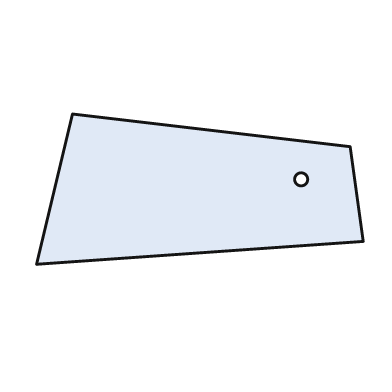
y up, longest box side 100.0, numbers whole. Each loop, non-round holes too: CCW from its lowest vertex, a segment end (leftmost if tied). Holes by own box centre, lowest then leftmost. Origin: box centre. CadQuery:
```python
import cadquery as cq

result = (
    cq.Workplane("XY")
    .moveTo(-50.0, -23.0)
    .lineTo(50.0, -16.0)
    .lineTo(46.0, 13.0)
    .lineTo(-39.0, 23.0)
    .close()
    .moveTo(31.0, 3.0)
    .circle(2.0)
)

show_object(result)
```